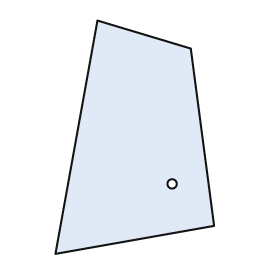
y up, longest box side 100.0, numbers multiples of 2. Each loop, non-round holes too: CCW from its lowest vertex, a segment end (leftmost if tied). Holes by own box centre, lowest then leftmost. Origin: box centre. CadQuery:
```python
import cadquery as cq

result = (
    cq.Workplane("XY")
    .moveTo(-34.0, -50.0)
    .lineTo(34.0, -38.0)
    .lineTo(24.0, 38.0)
    .lineTo(-16.0, 50.0)
    .close()
    .moveTo(16.0, -20.0)
    .circle(2.0)
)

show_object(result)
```